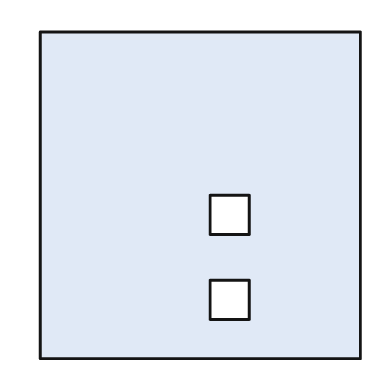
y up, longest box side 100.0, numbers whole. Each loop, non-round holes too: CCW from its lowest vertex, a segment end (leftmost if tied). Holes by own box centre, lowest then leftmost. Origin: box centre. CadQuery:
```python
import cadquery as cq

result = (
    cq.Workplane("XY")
    .moveTo(-49.0, -50.0)
    .lineTo(49.0, -50.0)
    .lineTo(49.0, 50.0)
    .lineTo(-49.0, 50.0)
    .close()
    .moveTo(3.0, -38.0)
    .lineTo(15.0, -38.0)
    .lineTo(15.0, -26.0)
    .lineTo(3.0, -26.0)
    .close()
    .moveTo(3.0, -12.0)
    .lineTo(15.0, -12.0)
    .lineTo(15.0, 0.0)
    .lineTo(3.0, 0.0)
    .close()
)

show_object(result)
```